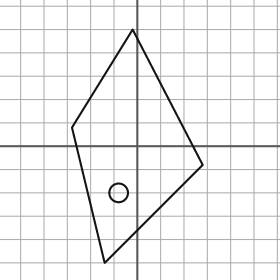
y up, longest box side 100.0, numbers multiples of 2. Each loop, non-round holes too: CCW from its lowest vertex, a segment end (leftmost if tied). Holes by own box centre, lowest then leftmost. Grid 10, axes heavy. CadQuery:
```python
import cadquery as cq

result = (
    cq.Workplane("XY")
    .moveTo(-14.0, -50.0)
    .lineTo(28.0, -8.0)
    .lineTo(-2.0, 50.0)
    .lineTo(-28.0, 8.0)
    .close()
    .moveTo(-8.0, -20.0)
    .circle(4.0)
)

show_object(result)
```